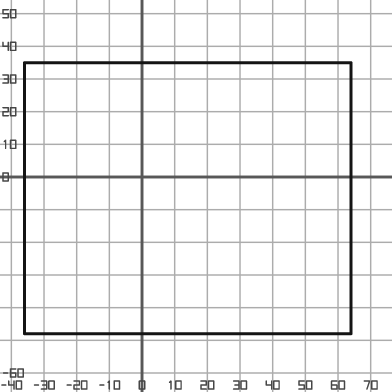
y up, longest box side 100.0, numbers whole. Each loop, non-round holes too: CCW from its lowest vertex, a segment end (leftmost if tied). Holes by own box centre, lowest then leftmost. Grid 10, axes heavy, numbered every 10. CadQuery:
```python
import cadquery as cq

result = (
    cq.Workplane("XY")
    .moveTo(-36.0, -48.0)
    .lineTo(64.0, -48.0)
    .lineTo(64.0, 35.0)
    .lineTo(-36.0, 35.0)
    .close()
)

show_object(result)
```